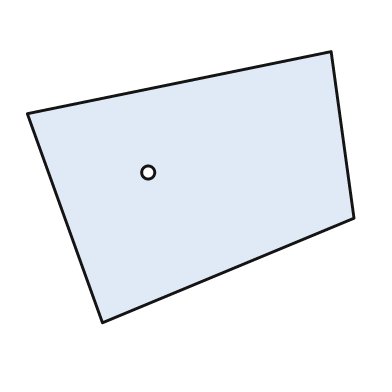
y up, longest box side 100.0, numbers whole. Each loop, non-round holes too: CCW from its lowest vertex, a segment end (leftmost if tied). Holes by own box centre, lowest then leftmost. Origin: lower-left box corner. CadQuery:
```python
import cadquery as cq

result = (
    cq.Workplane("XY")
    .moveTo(23.0, 0.0)
    .lineTo(100.0, 32.0)
    .lineTo(93.0, 83.0)
    .lineTo(0.0, 64.0)
    .close()
    .moveTo(37.0, 46.0)
    .circle(2.0)
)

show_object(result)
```